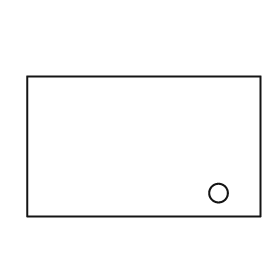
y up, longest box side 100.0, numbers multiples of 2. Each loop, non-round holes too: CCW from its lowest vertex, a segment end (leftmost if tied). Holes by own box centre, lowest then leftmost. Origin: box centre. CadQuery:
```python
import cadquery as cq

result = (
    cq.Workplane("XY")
    .moveTo(-50.0, -30.0)
    .lineTo(50.0, -30.0)
    .lineTo(50.0, 30.0)
    .lineTo(-50.0, 30.0)
    .close()
    .moveTo(32.0, -20.0)
    .circle(4.0)
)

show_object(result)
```